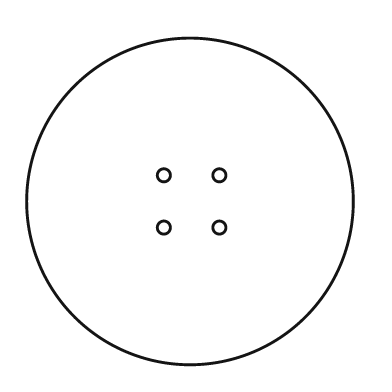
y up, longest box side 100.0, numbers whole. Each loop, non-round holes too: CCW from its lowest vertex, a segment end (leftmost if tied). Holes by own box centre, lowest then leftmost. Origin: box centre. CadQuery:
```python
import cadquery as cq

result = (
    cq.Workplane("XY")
    .moveTo(0.0, 0.0)
    .circle(50.0)
    .moveTo(-8.0, -8.0)
    .circle(2.0)
    .moveTo(9.0, -8.0)
    .circle(2.0)
    .moveTo(-8.0, 8.0)
    .circle(2.0)
    .moveTo(9.0, 8.0)
    .circle(2.0)
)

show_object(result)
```